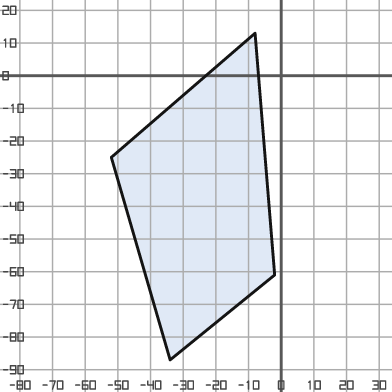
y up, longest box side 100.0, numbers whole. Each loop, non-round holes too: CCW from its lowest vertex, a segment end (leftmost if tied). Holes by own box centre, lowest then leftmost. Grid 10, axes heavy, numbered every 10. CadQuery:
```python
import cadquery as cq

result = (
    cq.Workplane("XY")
    .moveTo(-34.0, -87.0)
    .lineTo(-2.0, -61.0)
    .lineTo(-8.0, 13.0)
    .lineTo(-52.0, -25.0)
    .close()
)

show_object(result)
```